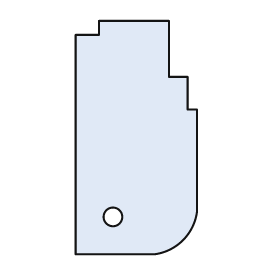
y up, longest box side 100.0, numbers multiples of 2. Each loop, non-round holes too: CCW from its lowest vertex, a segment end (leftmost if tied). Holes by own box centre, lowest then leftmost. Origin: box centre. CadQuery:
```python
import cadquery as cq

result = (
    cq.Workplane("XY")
    .moveTo(-26.0, -50.0)
    .lineTo(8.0, -50.0)
    .threePointArc((20.0, -44.0), (26.0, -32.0))
    .lineTo(26.0, 12.0)
    .lineTo(22.0, 12.0)
    .lineTo(22.0, 26.0)
    .lineTo(14.0, 26.0)
    .lineTo(14.0, 50.0)
    .lineTo(-16.0, 50.0)
    .lineTo(-16.0, 44.0)
    .lineTo(-26.0, 44.0)
    .close()
    .moveTo(-10.0, -34.0)
    .circle(4.0)
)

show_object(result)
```